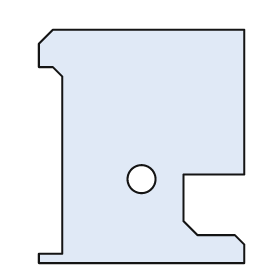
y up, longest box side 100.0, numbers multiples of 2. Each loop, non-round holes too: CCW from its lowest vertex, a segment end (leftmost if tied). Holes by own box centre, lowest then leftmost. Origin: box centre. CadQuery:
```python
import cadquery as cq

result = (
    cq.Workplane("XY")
    .moveTo(-44.0, -50.0)
    .lineTo(44.0, -50.0)
    .lineTo(44.0, -42.0)
    .lineTo(40.0, -38.0)
    .lineTo(24.0, -38.0)
    .lineTo(18.0, -32.0)
    .lineTo(18.0, -12.0)
    .lineTo(44.0, -12.0)
    .lineTo(44.0, 50.0)
    .lineTo(-38.0, 50.0)
    .lineTo(-44.0, 44.0)
    .lineTo(-44.0, 34.0)
    .lineTo(-38.0, 34.0)
    .lineTo(-34.0, 30.0)
    .lineTo(-34.0, -46.0)
    .lineTo(-44.0, -46.0)
    .close()
    .moveTo(0.0, -14.0)
    .circle(6.0)
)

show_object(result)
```